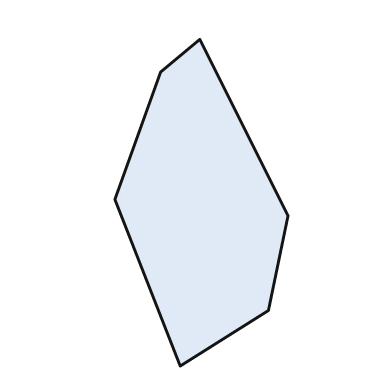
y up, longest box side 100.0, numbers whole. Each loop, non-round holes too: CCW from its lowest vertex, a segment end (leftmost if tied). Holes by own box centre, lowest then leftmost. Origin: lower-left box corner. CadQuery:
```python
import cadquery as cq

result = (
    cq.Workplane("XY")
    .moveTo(20.0, 0.0)
    .lineTo(47.0, 17.0)
    .lineTo(53.0, 46.0)
    .lineTo(26.0, 100.0)
    .lineTo(14.0, 90.0)
    .lineTo(0.0, 51.0)
    .close()
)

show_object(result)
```